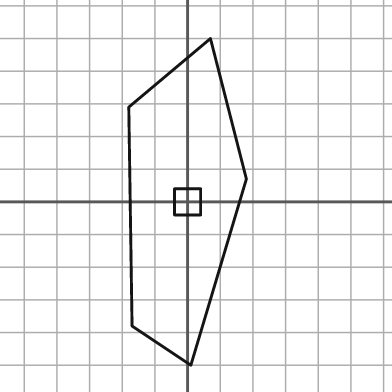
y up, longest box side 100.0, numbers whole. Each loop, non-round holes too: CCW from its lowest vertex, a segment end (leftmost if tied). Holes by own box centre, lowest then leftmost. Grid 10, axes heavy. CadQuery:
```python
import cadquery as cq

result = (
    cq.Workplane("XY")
    .moveTo(1.0, -50.0)
    .lineTo(18.0, 7.0)
    .lineTo(7.0, 50.0)
    .lineTo(-18.0, 29.0)
    .lineTo(-17.0, -38.0)
    .close()
    .moveTo(-4.0, -4.0)
    .lineTo(4.0, -4.0)
    .lineTo(4.0, 4.0)
    .lineTo(-4.0, 4.0)
    .close()
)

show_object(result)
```